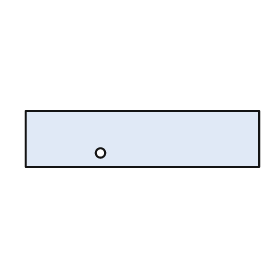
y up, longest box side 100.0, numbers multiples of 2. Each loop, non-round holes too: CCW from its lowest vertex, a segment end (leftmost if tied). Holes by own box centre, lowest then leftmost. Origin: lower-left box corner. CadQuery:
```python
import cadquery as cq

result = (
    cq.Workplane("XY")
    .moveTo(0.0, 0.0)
    .lineTo(100.0, 0.0)
    .lineTo(100.0, 24.0)
    .lineTo(0.0, 24.0)
    .close()
    .moveTo(32.0, 6.0)
    .circle(2.0)
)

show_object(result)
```